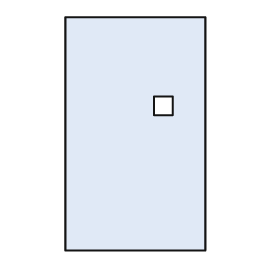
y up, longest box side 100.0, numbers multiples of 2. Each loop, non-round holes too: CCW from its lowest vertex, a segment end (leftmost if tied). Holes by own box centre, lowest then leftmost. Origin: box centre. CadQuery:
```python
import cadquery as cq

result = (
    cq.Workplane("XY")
    .moveTo(-30.0, -50.0)
    .lineTo(30.0, -50.0)
    .lineTo(30.0, 50.0)
    .lineTo(-30.0, 50.0)
    .close()
    .moveTo(8.0, 8.0)
    .lineTo(16.0, 8.0)
    .lineTo(16.0, 16.0)
    .lineTo(8.0, 16.0)
    .close()
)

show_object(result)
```